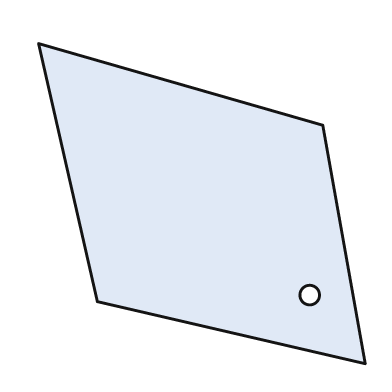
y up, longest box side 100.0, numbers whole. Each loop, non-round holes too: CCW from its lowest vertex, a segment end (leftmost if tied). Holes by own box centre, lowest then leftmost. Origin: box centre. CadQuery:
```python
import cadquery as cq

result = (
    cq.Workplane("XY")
    .moveTo(50.0, -49.0)
    .lineTo(37.0, 24.0)
    .lineTo(-50.0, 49.0)
    .lineTo(-32.0, -30.0)
    .close()
    .moveTo(33.0, -28.0)
    .circle(3.0)
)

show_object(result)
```